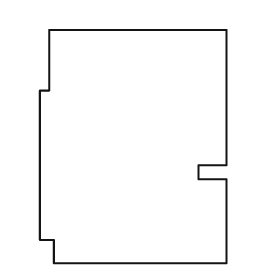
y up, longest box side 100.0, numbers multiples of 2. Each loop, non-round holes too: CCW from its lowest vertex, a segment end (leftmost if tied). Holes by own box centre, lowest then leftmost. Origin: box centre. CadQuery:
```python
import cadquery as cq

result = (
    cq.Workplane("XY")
    .moveTo(-34.0, -50.0)
    .lineTo(40.0, -50.0)
    .lineTo(40.0, -14.0)
    .lineTo(28.0, -14.0)
    .lineTo(28.0, -8.0)
    .lineTo(40.0, -8.0)
    .lineTo(40.0, 50.0)
    .lineTo(-36.0, 50.0)
    .lineTo(-36.0, 24.0)
    .lineTo(-40.0, 24.0)
    .lineTo(-40.0, -40.0)
    .lineTo(-34.0, -40.0)
    .close()
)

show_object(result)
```